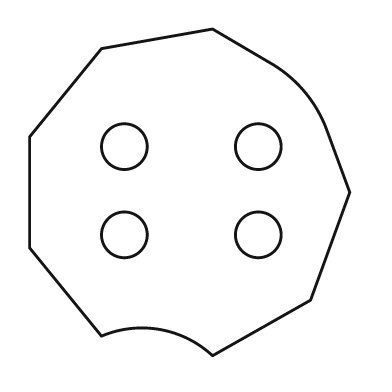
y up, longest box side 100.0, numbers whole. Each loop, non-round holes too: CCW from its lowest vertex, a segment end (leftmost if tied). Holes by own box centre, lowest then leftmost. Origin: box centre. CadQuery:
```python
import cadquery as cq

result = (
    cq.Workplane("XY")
    .moveTo(7.0, -50.0)
    .lineTo(37.0, -33.0)
    .lineTo(49.0, 0.0)
    .lineTo(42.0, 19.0)
    .threePointArc((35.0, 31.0), (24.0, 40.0))
    .lineTo(7.0, 50.0)
    .lineTo(-27.0, 44.0)
    .lineTo(-49.0, 17.0)
    .lineTo(-49.0, -17.0)
    .lineTo(-27.0, -44.0)
    .threePointArc((-9.0, -42.0), (7.0, -50.0))
    .close()
    .moveTo(-20.0, -13.0)
    .circle(7.0)
    .moveTo(21.0, -13.0)
    .circle(7.0)
    .moveTo(-20.0, 14.0)
    .circle(7.0)
    .moveTo(21.0, 14.0)
    .circle(7.0)
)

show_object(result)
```